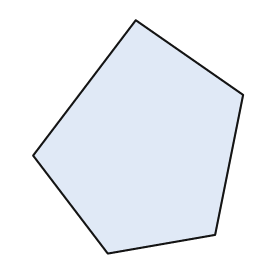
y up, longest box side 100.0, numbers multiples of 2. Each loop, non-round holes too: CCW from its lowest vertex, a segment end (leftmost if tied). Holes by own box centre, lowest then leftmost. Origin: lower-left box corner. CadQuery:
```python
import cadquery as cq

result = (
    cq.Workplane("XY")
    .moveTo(32.0, 0.0)
    .lineTo(78.0, 8.0)
    .lineTo(90.0, 68.0)
    .lineTo(44.0, 100.0)
    .lineTo(0.0, 42.0)
    .close()
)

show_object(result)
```